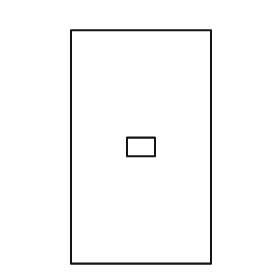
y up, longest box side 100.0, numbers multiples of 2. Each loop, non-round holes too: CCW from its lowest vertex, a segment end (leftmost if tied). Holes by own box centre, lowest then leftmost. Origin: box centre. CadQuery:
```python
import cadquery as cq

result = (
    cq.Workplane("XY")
    .moveTo(-30.0, -50.0)
    .lineTo(30.0, -50.0)
    .lineTo(30.0, 50.0)
    .lineTo(-30.0, 50.0)
    .close()
    .moveTo(-6.0, -4.0)
    .lineTo(6.0, -4.0)
    .lineTo(6.0, 4.0)
    .lineTo(-6.0, 4.0)
    .close()
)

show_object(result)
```